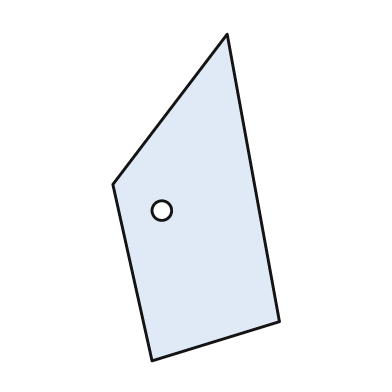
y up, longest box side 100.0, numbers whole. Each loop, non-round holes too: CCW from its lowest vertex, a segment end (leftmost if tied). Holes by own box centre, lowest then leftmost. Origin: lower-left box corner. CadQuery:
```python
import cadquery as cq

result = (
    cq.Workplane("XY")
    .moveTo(12.0, 0.0)
    .lineTo(51.0, 12.0)
    .lineTo(35.0, 100.0)
    .lineTo(0.0, 54.0)
    .close()
    .moveTo(15.0, 46.0)
    .circle(3.0)
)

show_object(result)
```